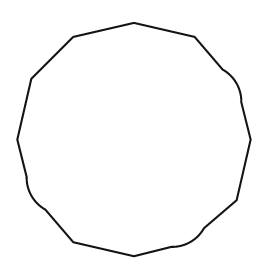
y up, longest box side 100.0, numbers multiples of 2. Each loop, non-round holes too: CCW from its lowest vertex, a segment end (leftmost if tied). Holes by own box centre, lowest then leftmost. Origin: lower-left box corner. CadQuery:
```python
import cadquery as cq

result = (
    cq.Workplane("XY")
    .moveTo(50.0, 0.0)
    .lineTo(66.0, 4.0)
    .threePointArc((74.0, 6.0), (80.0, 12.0))
    .lineTo(94.0, 24.0)
    .lineTo(100.0, 50.0)
    .lineTo(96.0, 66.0)
    .threePointArc((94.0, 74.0), (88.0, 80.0))
    .lineTo(76.0, 94.0)
    .lineTo(50.0, 100.0)
    .lineTo(24.0, 94.0)
    .lineTo(6.0, 76.0)
    .lineTo(0.0, 50.0)
    .lineTo(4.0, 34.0)
    .threePointArc((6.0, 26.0), (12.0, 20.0))
    .lineTo(24.0, 6.0)
    .close()
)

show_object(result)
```